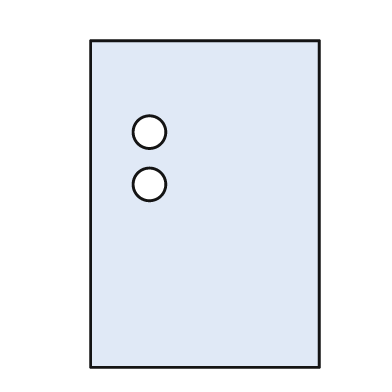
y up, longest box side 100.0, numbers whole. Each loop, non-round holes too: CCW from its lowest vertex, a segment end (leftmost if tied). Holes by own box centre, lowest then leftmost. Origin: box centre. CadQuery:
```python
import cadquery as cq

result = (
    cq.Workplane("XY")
    .moveTo(-35.0, -50.0)
    .lineTo(35.0, -50.0)
    .lineTo(35.0, 50.0)
    .lineTo(-35.0, 50.0)
    .close()
    .moveTo(-17.0, 6.0)
    .circle(5.0)
    .moveTo(-17.0, 22.0)
    .circle(5.0)
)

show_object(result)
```